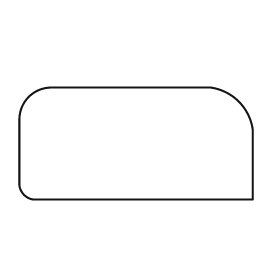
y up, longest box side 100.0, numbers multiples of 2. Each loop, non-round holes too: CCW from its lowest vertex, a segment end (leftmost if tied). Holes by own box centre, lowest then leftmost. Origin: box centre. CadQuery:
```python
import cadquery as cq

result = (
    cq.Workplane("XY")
    .moveTo(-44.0, -24.0)
    .lineTo(50.0, -24.0)
    .lineTo(50.0, 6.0)
    .threePointArc((44.0, 18.0), (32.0, 24.0))
    .lineTo(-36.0, 24.0)
    .threePointArc((-46.0, 20.0), (-50.0, 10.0))
    .lineTo(-50.0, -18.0)
    .threePointArc((-48.0, -22.0), (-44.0, -24.0))
    .close()
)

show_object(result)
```